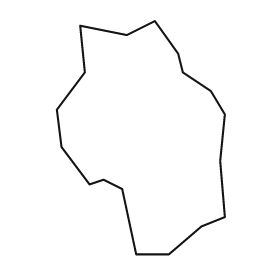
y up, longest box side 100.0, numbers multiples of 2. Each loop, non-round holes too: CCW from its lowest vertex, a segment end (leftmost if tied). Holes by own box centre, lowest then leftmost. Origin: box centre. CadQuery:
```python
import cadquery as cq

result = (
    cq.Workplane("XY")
    .moveTo(-2.0, -50.0)
    .lineTo(12.0, -50.0)
    .lineTo(26.0, -38.0)
    .lineTo(36.0, -34.0)
    .lineTo(34.0, -10.0)
    .lineTo(36.0, 10.0)
    .lineTo(30.0, 20.0)
    .lineTo(18.0, 28.0)
    .lineTo(16.0, 36.0)
    .lineTo(6.0, 50.0)
    .lineTo(-6.0, 44.0)
    .lineTo(-26.0, 48.0)
    .lineTo(-24.0, 28.0)
    .lineTo(-36.0, 12.0)
    .lineTo(-34.0, -4.0)
    .lineTo(-22.0, -20.0)
    .lineTo(-16.0, -18.0)
    .lineTo(-8.0, -22.0)
    .close()
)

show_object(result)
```